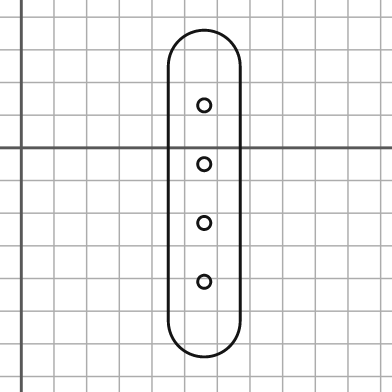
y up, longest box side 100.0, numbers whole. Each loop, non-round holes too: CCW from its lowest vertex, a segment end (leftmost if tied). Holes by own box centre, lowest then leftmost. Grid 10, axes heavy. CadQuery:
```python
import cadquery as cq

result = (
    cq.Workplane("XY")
    .moveTo(45.0, -53.0)
    .threePointArc((56.0, -64.0), (67.0, -53.0))
    .lineTo(67.0, 25.0)
    .threePointArc((56.0, 36.0), (45.0, 25.0))
    .close()
    .moveTo(56.0, -41.0)
    .circle(2.0)
    .moveTo(56.0, -23.0)
    .circle(2.0)
    .moveTo(56.0, -5.0)
    .circle(2.0)
    .moveTo(56.0, 13.0)
    .circle(2.0)
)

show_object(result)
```